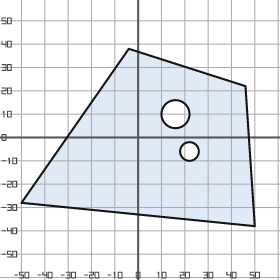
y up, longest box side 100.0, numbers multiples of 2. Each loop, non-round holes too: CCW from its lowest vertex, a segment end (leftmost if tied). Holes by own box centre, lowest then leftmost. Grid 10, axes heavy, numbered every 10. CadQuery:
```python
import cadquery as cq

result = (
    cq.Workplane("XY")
    .moveTo(50.0, -38.0)
    .lineTo(46.0, 22.0)
    .lineTo(-4.0, 38.0)
    .lineTo(-50.0, -28.0)
    .close()
    .moveTo(22.0, -6.0)
    .circle(4.0)
    .moveTo(16.0, 10.0)
    .circle(6.0)
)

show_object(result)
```